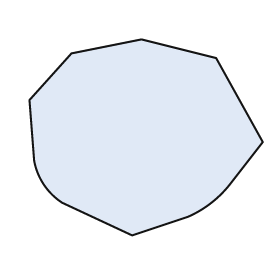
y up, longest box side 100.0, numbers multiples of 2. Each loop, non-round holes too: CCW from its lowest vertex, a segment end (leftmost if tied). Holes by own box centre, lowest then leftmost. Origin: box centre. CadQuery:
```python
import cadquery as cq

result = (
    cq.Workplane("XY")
    .moveTo(-6.0, -42.0)
    .lineTo(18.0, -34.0)
    .threePointArc((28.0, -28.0), (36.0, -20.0))
    .lineTo(50.0, -2.0)
    .lineTo(30.0, 34.0)
    .lineTo(-2.0, 42.0)
    .lineTo(-32.0, 36.0)
    .lineTo(-50.0, 16.0)
    .lineTo(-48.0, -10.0)
    .threePointArc((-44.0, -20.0), (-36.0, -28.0))
    .close()
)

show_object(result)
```